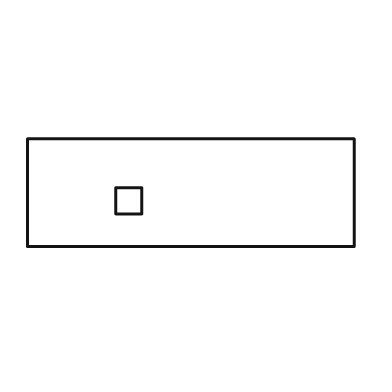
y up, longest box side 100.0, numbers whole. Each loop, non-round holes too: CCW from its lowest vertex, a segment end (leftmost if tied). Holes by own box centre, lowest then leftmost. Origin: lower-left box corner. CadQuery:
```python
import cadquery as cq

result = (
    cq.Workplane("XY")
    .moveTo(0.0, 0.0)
    .lineTo(100.0, 0.0)
    .lineTo(100.0, 33.0)
    .lineTo(0.0, 33.0)
    .close()
    .moveTo(27.0, 10.0)
    .lineTo(35.0, 10.0)
    .lineTo(35.0, 18.0)
    .lineTo(27.0, 18.0)
    .close()
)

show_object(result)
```